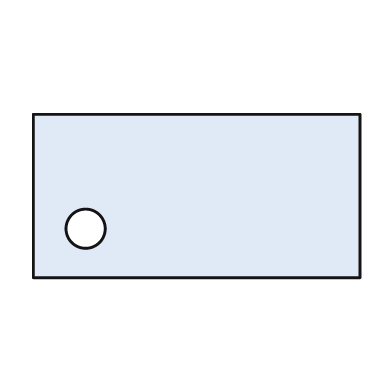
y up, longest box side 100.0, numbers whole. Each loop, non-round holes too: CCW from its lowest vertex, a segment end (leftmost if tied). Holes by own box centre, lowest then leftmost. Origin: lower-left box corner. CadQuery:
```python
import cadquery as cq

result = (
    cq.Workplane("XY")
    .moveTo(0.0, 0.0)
    .lineTo(100.0, 0.0)
    .lineTo(100.0, 50.0)
    .lineTo(0.0, 50.0)
    .close()
    .moveTo(16.0, 15.0)
    .circle(6.0)
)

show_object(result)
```